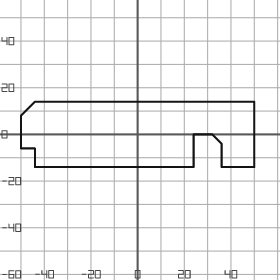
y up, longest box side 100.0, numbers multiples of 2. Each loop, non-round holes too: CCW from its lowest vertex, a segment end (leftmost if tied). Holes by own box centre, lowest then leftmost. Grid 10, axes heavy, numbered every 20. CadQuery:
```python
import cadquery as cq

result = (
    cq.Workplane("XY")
    .moveTo(-44.0, -14.0)
    .lineTo(24.0, -14.0)
    .lineTo(24.0, 0.0)
    .lineTo(32.0, 0.0)
    .lineTo(36.0, -4.0)
    .lineTo(36.0, -14.0)
    .lineTo(50.0, -14.0)
    .lineTo(50.0, 14.0)
    .lineTo(-44.0, 14.0)
    .lineTo(-50.0, 8.0)
    .lineTo(-50.0, -6.0)
    .lineTo(-44.0, -6.0)
    .close()
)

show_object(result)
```